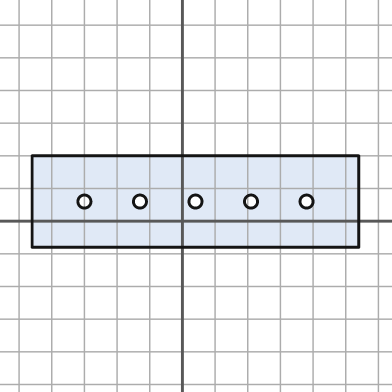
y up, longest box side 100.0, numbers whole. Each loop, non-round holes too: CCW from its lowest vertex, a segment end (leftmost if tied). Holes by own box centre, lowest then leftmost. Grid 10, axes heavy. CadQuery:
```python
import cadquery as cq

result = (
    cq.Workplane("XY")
    .moveTo(-46.0, -8.0)
    .lineTo(54.0, -8.0)
    .lineTo(54.0, 20.0)
    .lineTo(-46.0, 20.0)
    .close()
    .moveTo(-30.0, 6.0)
    .circle(2.0)
    .moveTo(-13.0, 6.0)
    .circle(2.0)
    .moveTo(4.0, 6.0)
    .circle(2.0)
    .moveTo(21.0, 6.0)
    .circle(2.0)
    .moveTo(38.0, 6.0)
    .circle(2.0)
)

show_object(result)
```